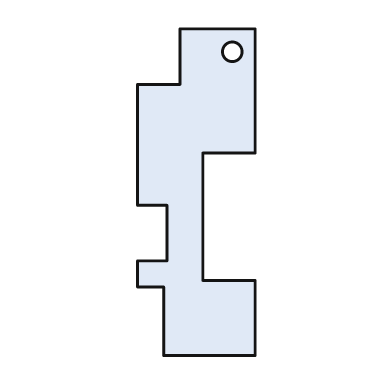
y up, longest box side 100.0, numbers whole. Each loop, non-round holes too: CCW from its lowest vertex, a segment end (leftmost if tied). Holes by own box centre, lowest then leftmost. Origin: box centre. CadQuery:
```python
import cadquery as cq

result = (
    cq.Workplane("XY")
    .moveTo(-10.0, -50.0)
    .lineTo(18.0, -50.0)
    .lineTo(18.0, -27.0)
    .lineTo(2.0, -27.0)
    .lineTo(2.0, 12.0)
    .lineTo(18.0, 12.0)
    .lineTo(18.0, 50.0)
    .lineTo(-5.0, 50.0)
    .lineTo(-5.0, 33.0)
    .lineTo(-18.0, 33.0)
    .lineTo(-18.0, -4.0)
    .lineTo(-9.0, -4.0)
    .lineTo(-9.0, -21.0)
    .lineTo(-18.0, -21.0)
    .lineTo(-18.0, -29.0)
    .lineTo(-10.0, -29.0)
    .close()
    .moveTo(11.0, 43.0)
    .circle(3.0)
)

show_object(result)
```